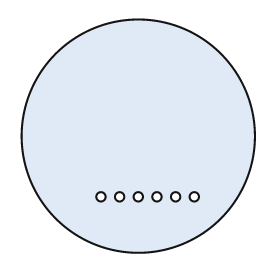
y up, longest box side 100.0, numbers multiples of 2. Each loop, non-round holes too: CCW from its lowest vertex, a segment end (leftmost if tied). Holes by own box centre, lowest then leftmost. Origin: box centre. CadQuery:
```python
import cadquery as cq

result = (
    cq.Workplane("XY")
    .moveTo(0.0, 0.0)
    .circle(50.0)
    .moveTo(-16.0, -26.0)
    .circle(2.0)
    .moveTo(-8.0, -26.0)
    .circle(2.0)
    .moveTo(0.0, -26.0)
    .circle(2.0)
    .moveTo(8.0, -26.0)
    .circle(2.0)
    .moveTo(16.0, -26.0)
    .circle(2.0)
    .moveTo(24.0, -26.0)
    .circle(2.0)
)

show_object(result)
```